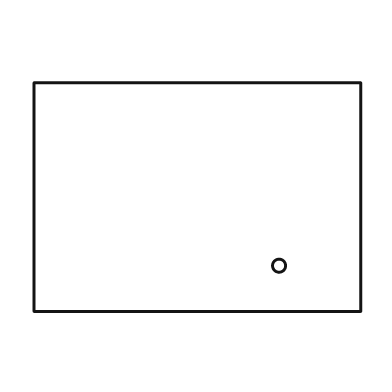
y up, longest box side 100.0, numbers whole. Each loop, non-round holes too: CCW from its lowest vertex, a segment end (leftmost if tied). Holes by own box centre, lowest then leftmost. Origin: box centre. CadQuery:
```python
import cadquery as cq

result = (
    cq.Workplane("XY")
    .moveTo(-50.0, -35.0)
    .lineTo(50.0, -35.0)
    .lineTo(50.0, 35.0)
    .lineTo(-50.0, 35.0)
    .close()
    .moveTo(25.0, -21.0)
    .circle(2.0)
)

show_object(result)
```